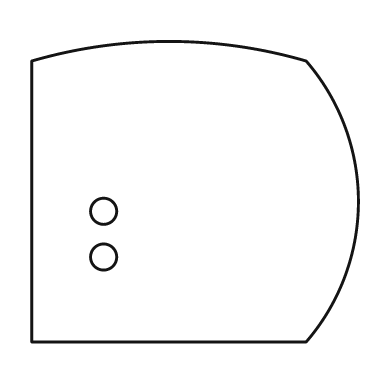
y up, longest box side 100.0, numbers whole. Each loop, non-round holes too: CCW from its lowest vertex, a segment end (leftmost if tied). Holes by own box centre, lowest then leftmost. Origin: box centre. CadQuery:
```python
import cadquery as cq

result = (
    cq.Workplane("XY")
    .moveTo(-50.0, -46.0)
    .lineTo(34.0, -46.0)
    .threePointArc((50.0, -3.0), (34.0, 40.0))
    .threePointArc((-8.0, 46.0), (-50.0, 40.0))
    .close()
    .moveTo(-28.0, -20.0)
    .circle(4.0)
    .moveTo(-28.0, -6.0)
    .circle(4.0)
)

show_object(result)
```